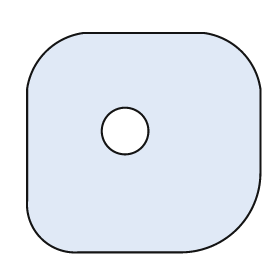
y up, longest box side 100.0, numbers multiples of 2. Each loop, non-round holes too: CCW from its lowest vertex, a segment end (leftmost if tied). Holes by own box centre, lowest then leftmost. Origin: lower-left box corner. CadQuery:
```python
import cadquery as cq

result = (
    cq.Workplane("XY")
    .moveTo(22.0, 0.0)
    .lineTo(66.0, 0.0)
    .threePointArc((90.0, 10.0), (100.0, 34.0))
    .lineTo(100.0, 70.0)
    .threePointArc((92.0, 86.0), (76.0, 94.0))
    .lineTo(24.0, 94.0)
    .threePointArc((8.0, 86.0), (0.0, 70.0))
    .lineTo(0.0, 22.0)
    .threePointArc((6.0, 6.0), (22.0, 0.0))
    .close()
    .moveTo(42.0, 52.0)
    .circle(10.0)
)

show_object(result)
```